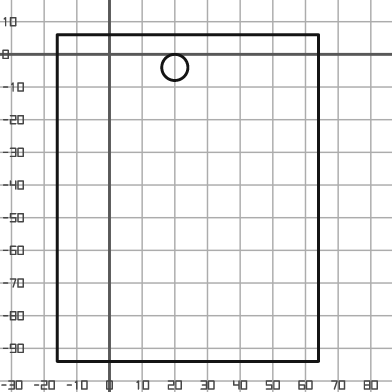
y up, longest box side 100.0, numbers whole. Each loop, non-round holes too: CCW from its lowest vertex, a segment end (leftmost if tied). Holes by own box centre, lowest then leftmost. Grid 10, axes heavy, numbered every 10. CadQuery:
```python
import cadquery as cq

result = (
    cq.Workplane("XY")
    .moveTo(-16.0, -94.0)
    .lineTo(64.0, -94.0)
    .lineTo(64.0, 6.0)
    .lineTo(-16.0, 6.0)
    .close()
    .moveTo(20.0, -4.0)
    .circle(4.0)
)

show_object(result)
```